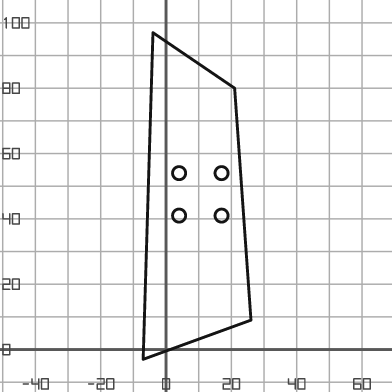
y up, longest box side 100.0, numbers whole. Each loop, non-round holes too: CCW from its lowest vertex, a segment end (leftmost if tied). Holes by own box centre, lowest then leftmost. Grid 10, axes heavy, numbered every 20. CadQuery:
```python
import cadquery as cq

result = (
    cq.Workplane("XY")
    .moveTo(-7.0, -3.0)
    .lineTo(26.0, 9.0)
    .lineTo(21.0, 80.0)
    .lineTo(-4.0, 97.0)
    .close()
    .moveTo(4.0, 41.0)
    .circle(2.0)
    .moveTo(17.0, 41.0)
    .circle(2.0)
    .moveTo(4.0, 54.0)
    .circle(2.0)
    .moveTo(17.0, 54.0)
    .circle(2.0)
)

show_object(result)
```